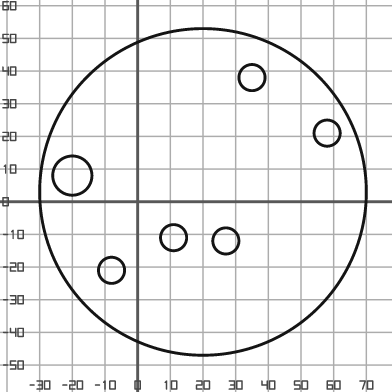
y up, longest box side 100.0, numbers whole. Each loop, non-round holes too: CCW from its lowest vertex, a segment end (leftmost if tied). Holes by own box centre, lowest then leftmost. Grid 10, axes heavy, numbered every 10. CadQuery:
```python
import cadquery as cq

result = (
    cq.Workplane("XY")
    .moveTo(20.0, 3.0)
    .circle(50.0)
    .moveTo(-8.0, -21.0)
    .circle(4.0)
    .moveTo(27.0, -12.0)
    .circle(4.0)
    .moveTo(11.0, -11.0)
    .circle(4.0)
    .moveTo(-20.0, 8.0)
    .circle(6.0)
    .moveTo(58.0, 21.0)
    .circle(4.0)
    .moveTo(35.0, 38.0)
    .circle(4.0)
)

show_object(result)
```